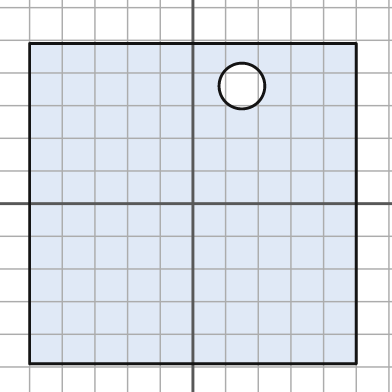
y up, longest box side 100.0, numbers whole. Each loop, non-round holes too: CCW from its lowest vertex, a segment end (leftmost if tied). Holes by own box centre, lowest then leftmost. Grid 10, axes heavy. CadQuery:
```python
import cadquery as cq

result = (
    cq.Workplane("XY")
    .moveTo(-50.0, -49.0)
    .lineTo(50.0, -49.0)
    .lineTo(50.0, 49.0)
    .lineTo(-50.0, 49.0)
    .close()
    .moveTo(15.0, 36.0)
    .circle(7.0)
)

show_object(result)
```